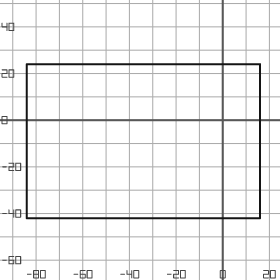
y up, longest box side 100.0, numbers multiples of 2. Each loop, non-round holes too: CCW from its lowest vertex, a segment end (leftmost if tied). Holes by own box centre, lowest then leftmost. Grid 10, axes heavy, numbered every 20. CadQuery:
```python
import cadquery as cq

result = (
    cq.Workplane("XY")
    .moveTo(-84.0, -42.0)
    .lineTo(16.0, -42.0)
    .lineTo(16.0, 24.0)
    .lineTo(-84.0, 24.0)
    .close()
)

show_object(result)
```